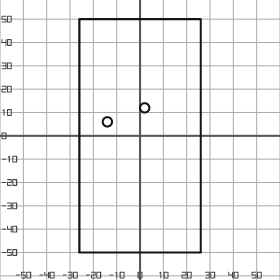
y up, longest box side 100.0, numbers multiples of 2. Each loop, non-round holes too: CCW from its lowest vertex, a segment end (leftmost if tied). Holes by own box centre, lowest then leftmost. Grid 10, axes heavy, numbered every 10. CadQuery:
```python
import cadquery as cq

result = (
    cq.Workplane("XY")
    .moveTo(-26.0, -50.0)
    .lineTo(26.0, -50.0)
    .lineTo(26.0, 50.0)
    .lineTo(-26.0, 50.0)
    .close()
    .moveTo(-14.0, 6.0)
    .circle(2.0)
    .moveTo(2.0, 12.0)
    .circle(2.0)
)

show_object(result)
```